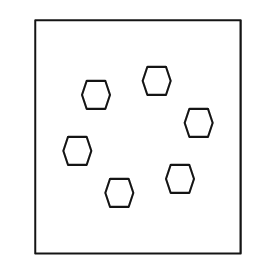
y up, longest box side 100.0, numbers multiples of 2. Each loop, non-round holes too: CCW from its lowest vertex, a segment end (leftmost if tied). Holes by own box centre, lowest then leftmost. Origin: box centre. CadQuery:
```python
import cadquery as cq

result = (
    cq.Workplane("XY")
    .moveTo(-44.0, -50.0)
    .lineTo(44.0, -50.0)
    .lineTo(44.0, 50.0)
    .lineTo(-44.0, 50.0)
    .close()
    .moveTo(-12.0, -30.0)
    .lineTo(-4.0, -30.0)
    .lineTo(-2.0, -24.0)
    .lineTo(-4.0, -18.0)
    .lineTo(-12.0, -18.0)
    .lineTo(-14.0, -24.0)
    .close()
    .moveTo(14.0, -24.0)
    .lineTo(22.0, -24.0)
    .lineTo(24.0, -18.0)
    .lineTo(22.0, -12.0)
    .lineTo(14.0, -12.0)
    .lineTo(12.0, -18.0)
    .close()
    .moveTo(-30.0, -12.0)
    .lineTo(-22.0, -12.0)
    .lineTo(-20.0, -6.0)
    .lineTo(-22.0, 0.0)
    .lineTo(-30.0, 0.0)
    .lineTo(-32.0, -6.0)
    .close()
    .moveTo(22.0, 0.0)
    .lineTo(30.0, 0.0)
    .lineTo(32.0, 6.0)
    .lineTo(30.0, 12.0)
    .lineTo(22.0, 12.0)
    .lineTo(20.0, 6.0)
    .close()
    .moveTo(-22.0, 12.0)
    .lineTo(-14.0, 12.0)
    .lineTo(-12.0, 18.0)
    .lineTo(-14.0, 24.0)
    .lineTo(-22.0, 24.0)
    .lineTo(-24.0, 18.0)
    .close()
    .moveTo(4.0, 18.0)
    .lineTo(12.0, 18.0)
    .lineTo(14.0, 24.0)
    .lineTo(12.0, 30.0)
    .lineTo(4.0, 30.0)
    .lineTo(2.0, 24.0)
    .close()
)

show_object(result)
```